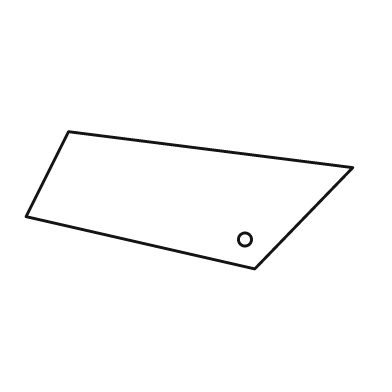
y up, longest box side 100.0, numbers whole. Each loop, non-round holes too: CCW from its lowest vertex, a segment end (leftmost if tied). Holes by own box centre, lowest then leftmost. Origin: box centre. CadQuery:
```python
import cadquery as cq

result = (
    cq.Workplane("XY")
    .moveTo(20.0, -21.0)
    .lineTo(50.0, 10.0)
    .lineTo(-37.0, 21.0)
    .lineTo(-50.0, -5.0)
    .close()
    .moveTo(17.0, -12.0)
    .circle(2.0)
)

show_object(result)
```